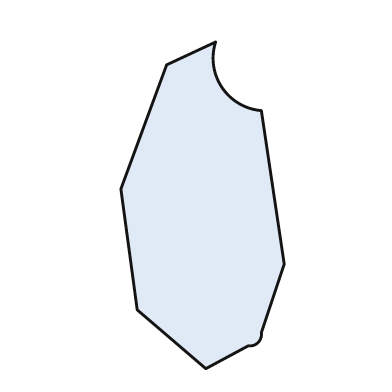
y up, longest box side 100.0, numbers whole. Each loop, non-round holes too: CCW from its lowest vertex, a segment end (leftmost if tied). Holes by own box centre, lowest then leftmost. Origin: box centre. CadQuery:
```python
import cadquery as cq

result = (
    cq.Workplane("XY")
    .moveTo(1.0, -50.0)
    .lineTo(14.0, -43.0)
    .threePointArc((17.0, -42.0), (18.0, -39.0))
    .lineTo(25.0, -18.0)
    .lineTo(18.0, 29.0)
    .threePointArc((6.0, 36.0), (4.0, 50.0))
    .lineTo(-11.0, 43.0)
    .lineTo(-25.0, 5.0)
    .lineTo(-20.0, -32.0)
    .close()
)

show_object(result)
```